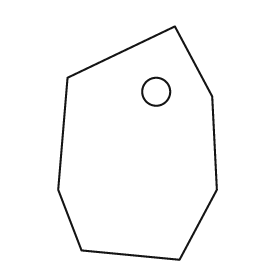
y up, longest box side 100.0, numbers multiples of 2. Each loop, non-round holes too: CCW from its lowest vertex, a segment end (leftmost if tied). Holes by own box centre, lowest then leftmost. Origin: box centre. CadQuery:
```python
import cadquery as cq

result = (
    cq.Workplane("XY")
    .moveTo(18.0, -50.0)
    .lineTo(34.0, -20.0)
    .lineTo(32.0, 20.0)
    .lineTo(16.0, 50.0)
    .lineTo(-30.0, 28.0)
    .lineTo(-34.0, -20.0)
    .lineTo(-24.0, -46.0)
    .close()
    .moveTo(8.0, 22.0)
    .circle(6.0)
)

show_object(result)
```